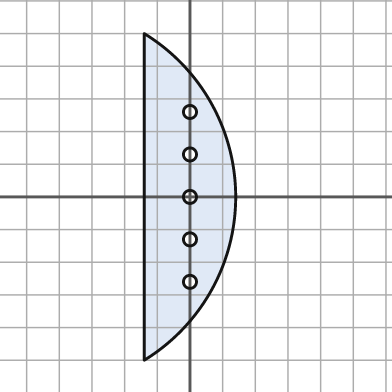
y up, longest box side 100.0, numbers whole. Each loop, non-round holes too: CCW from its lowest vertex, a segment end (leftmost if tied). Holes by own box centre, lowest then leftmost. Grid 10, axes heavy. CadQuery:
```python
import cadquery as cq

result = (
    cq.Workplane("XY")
    .moveTo(-14.0, -50.0)
    .threePointArc((14.0, 0.0), (-14.0, 50.0))
    .close()
    .moveTo(0.0, -26.0)
    .circle(2.0)
    .moveTo(0.0, -13.0)
    .circle(2.0)
    .moveTo(0.0, 0.0)
    .circle(2.0)
    .moveTo(0.0, 13.0)
    .circle(2.0)
    .moveTo(0.0, 26.0)
    .circle(2.0)
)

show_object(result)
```